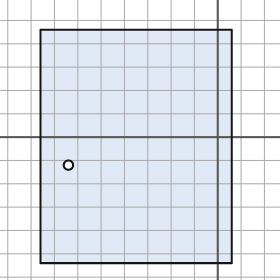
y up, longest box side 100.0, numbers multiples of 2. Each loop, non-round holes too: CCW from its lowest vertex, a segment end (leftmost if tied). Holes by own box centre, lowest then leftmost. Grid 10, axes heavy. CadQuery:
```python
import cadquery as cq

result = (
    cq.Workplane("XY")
    .moveTo(-76.0, -54.0)
    .lineTo(6.0, -54.0)
    .lineTo(6.0, 46.0)
    .lineTo(-76.0, 46.0)
    .close()
    .moveTo(-64.0, -12.0)
    .circle(2.0)
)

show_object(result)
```